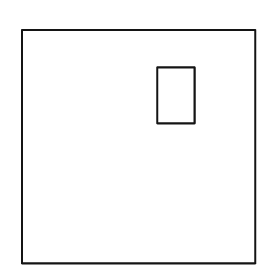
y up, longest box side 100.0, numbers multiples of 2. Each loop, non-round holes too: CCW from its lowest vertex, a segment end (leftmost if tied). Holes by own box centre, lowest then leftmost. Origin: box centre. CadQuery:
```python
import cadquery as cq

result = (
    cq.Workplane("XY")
    .moveTo(-50.0, -50.0)
    .lineTo(50.0, -50.0)
    .lineTo(50.0, 50.0)
    .lineTo(-50.0, 50.0)
    .close()
    .moveTo(8.0, 10.0)
    .lineTo(24.0, 10.0)
    .lineTo(24.0, 34.0)
    .lineTo(8.0, 34.0)
    .close()
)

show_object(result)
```